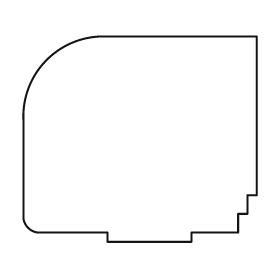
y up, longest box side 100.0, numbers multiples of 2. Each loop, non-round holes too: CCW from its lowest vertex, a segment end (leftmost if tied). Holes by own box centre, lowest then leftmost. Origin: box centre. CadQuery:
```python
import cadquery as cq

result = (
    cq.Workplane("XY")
    .moveTo(-14.0, -44.0)
    .lineTo(22.0, -44.0)
    .lineTo(22.0, -40.0)
    .lineTo(42.0, -40.0)
    .lineTo(42.0, -32.0)
    .lineTo(46.0, -32.0)
    .lineTo(46.0, -24.0)
    .lineTo(50.0, -24.0)
    .lineTo(50.0, 44.0)
    .lineTo(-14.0, 44.0)
    .threePointArc((-40.0, 34.0), (-50.0, 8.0))
    .lineTo(-50.0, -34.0)
    .threePointArc((-48.0, -38.0), (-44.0, -40.0))
    .lineTo(-14.0, -40.0)
    .close()
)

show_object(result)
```